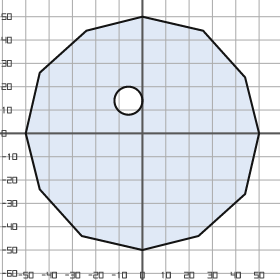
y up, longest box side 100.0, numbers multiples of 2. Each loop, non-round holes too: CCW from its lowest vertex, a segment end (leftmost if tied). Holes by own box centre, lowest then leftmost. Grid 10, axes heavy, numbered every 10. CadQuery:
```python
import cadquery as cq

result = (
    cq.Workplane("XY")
    .moveTo(0.0, -50.0)
    .lineTo(24.0, -44.0)
    .lineTo(44.0, -26.0)
    .lineTo(50.0, 0.0)
    .lineTo(44.0, 24.0)
    .lineTo(26.0, 44.0)
    .lineTo(0.0, 50.0)
    .lineTo(-24.0, 44.0)
    .lineTo(-44.0, 26.0)
    .lineTo(-50.0, 0.0)
    .lineTo(-44.0, -24.0)
    .lineTo(-26.0, -44.0)
    .close()
    .moveTo(-6.0, 14.0)
    .circle(6.0)
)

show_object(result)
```